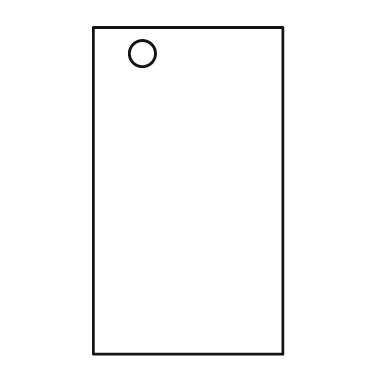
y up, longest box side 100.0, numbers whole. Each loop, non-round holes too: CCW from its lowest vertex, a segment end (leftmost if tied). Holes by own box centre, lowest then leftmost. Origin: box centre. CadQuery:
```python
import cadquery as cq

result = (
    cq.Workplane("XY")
    .moveTo(-29.0, -50.0)
    .lineTo(29.0, -50.0)
    .lineTo(29.0, 50.0)
    .lineTo(-29.0, 50.0)
    .close()
    .moveTo(-14.0, 42.0)
    .circle(4.0)
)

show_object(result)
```